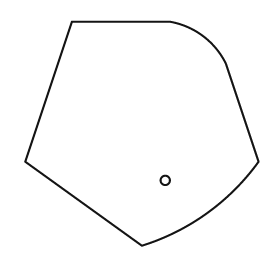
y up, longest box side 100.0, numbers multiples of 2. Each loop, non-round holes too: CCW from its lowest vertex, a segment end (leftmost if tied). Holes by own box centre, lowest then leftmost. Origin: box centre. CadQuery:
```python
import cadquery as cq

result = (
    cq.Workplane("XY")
    .moveTo(0.0, -48.0)
    .threePointArc((28.0, -34.0), (50.0, -12.0))
    .lineTo(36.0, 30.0)
    .threePointArc((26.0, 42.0), (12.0, 48.0))
    .lineTo(-30.0, 48.0)
    .lineTo(-50.0, -12.0)
    .close()
    .moveTo(10.0, -20.0)
    .circle(2.0)
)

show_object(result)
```